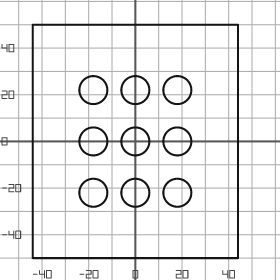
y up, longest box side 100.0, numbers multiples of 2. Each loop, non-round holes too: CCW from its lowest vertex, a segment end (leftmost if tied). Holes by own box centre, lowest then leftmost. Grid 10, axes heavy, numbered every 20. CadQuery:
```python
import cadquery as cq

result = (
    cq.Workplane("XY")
    .moveTo(-44.0, -50.0)
    .lineTo(44.0, -50.0)
    .lineTo(44.0, 50.0)
    .lineTo(-44.0, 50.0)
    .close()
    .moveTo(-18.0, -22.0)
    .circle(6.0)
    .moveTo(0.0, -22.0)
    .circle(6.0)
    .moveTo(18.0, -22.0)
    .circle(6.0)
    .moveTo(-18.0, 0.0)
    .circle(6.0)
    .moveTo(0.0, 0.0)
    .circle(6.0)
    .moveTo(18.0, 0.0)
    .circle(6.0)
    .moveTo(-18.0, 22.0)
    .circle(6.0)
    .moveTo(0.0, 22.0)
    .circle(6.0)
    .moveTo(18.0, 22.0)
    .circle(6.0)
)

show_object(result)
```